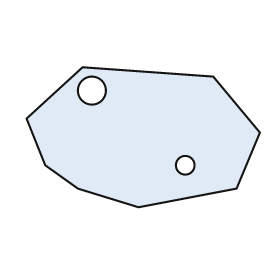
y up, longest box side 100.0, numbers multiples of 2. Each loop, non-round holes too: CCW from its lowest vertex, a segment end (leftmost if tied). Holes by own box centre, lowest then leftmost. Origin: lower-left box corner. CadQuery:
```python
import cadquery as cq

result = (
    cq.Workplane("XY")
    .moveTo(48.0, 0.0)
    .lineTo(90.0, 8.0)
    .lineTo(100.0, 32.0)
    .lineTo(80.0, 56.0)
    .lineTo(24.0, 60.0)
    .lineTo(0.0, 38.0)
    .lineTo(8.0, 18.0)
    .lineTo(22.0, 8.0)
    .close()
    .moveTo(68.0, 18.0)
    .circle(4.0)
    .moveTo(28.0, 50.0)
    .circle(6.0)
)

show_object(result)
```